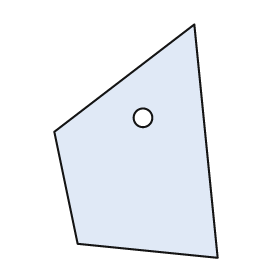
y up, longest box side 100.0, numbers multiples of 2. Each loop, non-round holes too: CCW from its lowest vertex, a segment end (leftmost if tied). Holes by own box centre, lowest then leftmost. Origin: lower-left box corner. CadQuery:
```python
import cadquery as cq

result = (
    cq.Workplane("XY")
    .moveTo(70.0, 0.0)
    .lineTo(60.0, 100.0)
    .lineTo(0.0, 54.0)
    .lineTo(10.0, 6.0)
    .close()
    .moveTo(38.0, 60.0)
    .circle(4.0)
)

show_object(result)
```